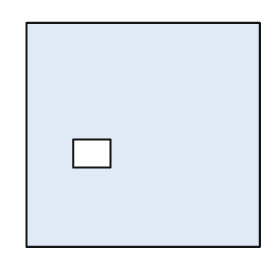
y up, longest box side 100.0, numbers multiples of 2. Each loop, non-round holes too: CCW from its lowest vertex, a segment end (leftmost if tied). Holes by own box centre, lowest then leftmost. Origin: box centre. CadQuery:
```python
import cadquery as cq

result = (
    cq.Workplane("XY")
    .moveTo(-50.0, -48.0)
    .lineTo(50.0, -48.0)
    .lineTo(50.0, 48.0)
    .lineTo(-50.0, 48.0)
    .close()
    .moveTo(-30.0, -14.0)
    .lineTo(-14.0, -14.0)
    .lineTo(-14.0, -2.0)
    .lineTo(-30.0, -2.0)
    .close()
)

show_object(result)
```